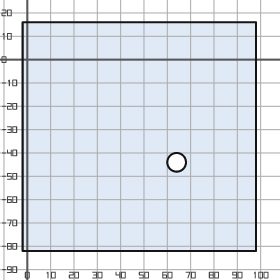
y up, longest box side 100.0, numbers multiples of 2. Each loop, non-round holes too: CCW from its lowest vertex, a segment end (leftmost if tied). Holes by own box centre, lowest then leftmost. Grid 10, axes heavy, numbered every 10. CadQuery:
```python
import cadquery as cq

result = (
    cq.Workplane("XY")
    .moveTo(-2.0, -82.0)
    .lineTo(98.0, -82.0)
    .lineTo(98.0, 16.0)
    .lineTo(-2.0, 16.0)
    .close()
    .moveTo(64.0, -44.0)
    .circle(4.0)
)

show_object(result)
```